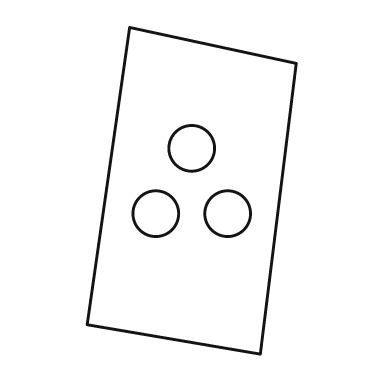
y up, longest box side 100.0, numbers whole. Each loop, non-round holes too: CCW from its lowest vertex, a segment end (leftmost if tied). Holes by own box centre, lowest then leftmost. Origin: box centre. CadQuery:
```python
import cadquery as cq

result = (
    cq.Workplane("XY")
    .moveTo(21.0, -50.0)
    .lineTo(32.0, 39.0)
    .lineTo(-19.0, 50.0)
    .lineTo(-32.0, -41.0)
    .close()
    .moveTo(-11.0, -7.0)
    .circle(7.0)
    .moveTo(11.0, -7.0)
    .circle(7.0)
    .moveTo(0.0, 13.0)
    .circle(7.0)
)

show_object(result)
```